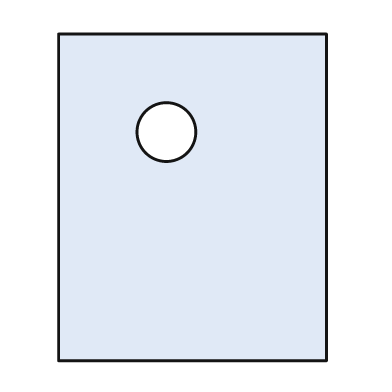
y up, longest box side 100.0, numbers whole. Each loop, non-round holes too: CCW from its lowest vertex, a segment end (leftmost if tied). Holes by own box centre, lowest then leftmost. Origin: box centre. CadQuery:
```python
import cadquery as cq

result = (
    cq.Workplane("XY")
    .moveTo(-41.0, -50.0)
    .lineTo(41.0, -50.0)
    .lineTo(41.0, 50.0)
    .lineTo(-41.0, 50.0)
    .close()
    .moveTo(-8.0, 20.0)
    .circle(9.0)
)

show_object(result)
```